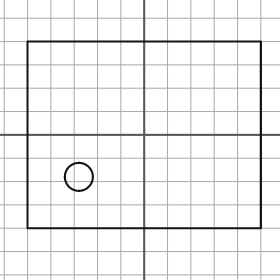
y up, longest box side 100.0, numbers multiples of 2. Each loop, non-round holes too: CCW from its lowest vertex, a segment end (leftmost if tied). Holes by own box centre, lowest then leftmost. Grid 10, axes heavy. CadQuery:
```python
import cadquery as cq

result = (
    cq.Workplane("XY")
    .moveTo(-50.0, -40.0)
    .lineTo(50.0, -40.0)
    .lineTo(50.0, 40.0)
    .lineTo(-50.0, 40.0)
    .close()
    .moveTo(-28.0, -18.0)
    .circle(6.0)
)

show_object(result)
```